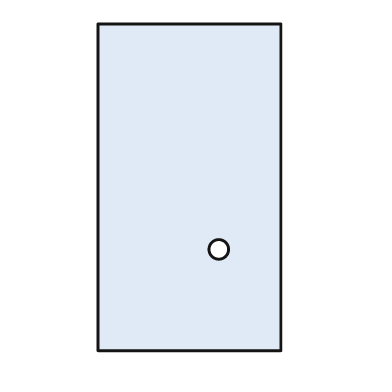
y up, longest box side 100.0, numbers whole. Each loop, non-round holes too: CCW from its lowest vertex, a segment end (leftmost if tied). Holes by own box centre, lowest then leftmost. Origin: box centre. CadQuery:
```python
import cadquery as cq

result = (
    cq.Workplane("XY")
    .moveTo(-28.0, -50.0)
    .lineTo(28.0, -50.0)
    .lineTo(28.0, 50.0)
    .lineTo(-28.0, 50.0)
    .close()
    .moveTo(9.0, -19.0)
    .circle(3.0)
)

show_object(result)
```